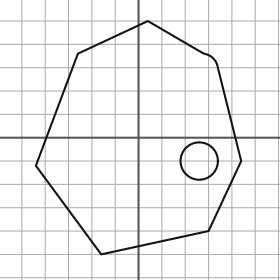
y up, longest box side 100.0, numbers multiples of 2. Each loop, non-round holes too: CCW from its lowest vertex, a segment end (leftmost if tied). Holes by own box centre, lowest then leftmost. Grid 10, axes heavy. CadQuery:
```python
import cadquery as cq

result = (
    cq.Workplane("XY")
    .moveTo(-16.0, -50.0)
    .lineTo(30.0, -40.0)
    .lineTo(44.0, -10.0)
    .lineTo(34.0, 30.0)
    .threePointArc((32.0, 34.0), (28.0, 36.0))
    .lineTo(4.0, 50.0)
    .lineTo(-26.0, 36.0)
    .lineTo(-44.0, -12.0)
    .close()
    .moveTo(26.0, -10.0)
    .circle(8.0)
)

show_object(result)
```